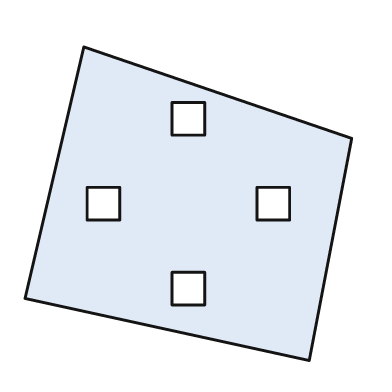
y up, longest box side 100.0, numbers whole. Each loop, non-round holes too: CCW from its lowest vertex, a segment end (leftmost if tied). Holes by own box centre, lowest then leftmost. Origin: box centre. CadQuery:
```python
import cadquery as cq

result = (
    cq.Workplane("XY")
    .moveTo(37.0, -48.0)
    .lineTo(50.0, 20.0)
    .lineTo(-32.0, 48.0)
    .lineTo(-50.0, -29.0)
    .close()
    .moveTo(-5.0, -31.0)
    .lineTo(5.0, -31.0)
    .lineTo(5.0, -21.0)
    .lineTo(-5.0, -21.0)
    .close()
    .moveTo(-31.0, -5.0)
    .lineTo(-21.0, -5.0)
    .lineTo(-21.0, 5.0)
    .lineTo(-31.0, 5.0)
    .close()
    .moveTo(21.0, -5.0)
    .lineTo(31.0, -5.0)
    .lineTo(31.0, 5.0)
    .lineTo(21.0, 5.0)
    .close()
    .moveTo(-5.0, 21.0)
    .lineTo(5.0, 21.0)
    .lineTo(5.0, 31.0)
    .lineTo(-5.0, 31.0)
    .close()
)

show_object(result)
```